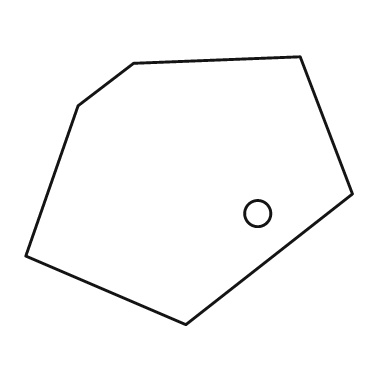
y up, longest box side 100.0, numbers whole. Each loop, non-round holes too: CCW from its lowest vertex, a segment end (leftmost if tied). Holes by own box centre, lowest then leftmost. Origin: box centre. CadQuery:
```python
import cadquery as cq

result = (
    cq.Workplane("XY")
    .moveTo(-1.0, -41.0)
    .lineTo(50.0, -1.0)
    .lineTo(34.0, 41.0)
    .lineTo(-17.0, 39.0)
    .lineTo(-34.0, 26.0)
    .lineTo(-50.0, -20.0)
    .close()
    .moveTo(21.0, -7.0)
    .circle(4.0)
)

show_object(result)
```